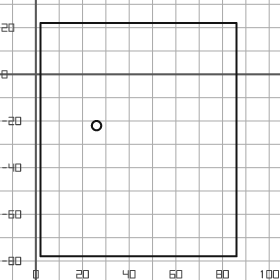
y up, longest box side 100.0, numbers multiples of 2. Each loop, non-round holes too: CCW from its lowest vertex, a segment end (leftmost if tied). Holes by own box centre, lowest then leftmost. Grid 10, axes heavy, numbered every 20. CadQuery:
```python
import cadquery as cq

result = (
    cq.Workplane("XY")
    .moveTo(2.0, -78.0)
    .lineTo(86.0, -78.0)
    .lineTo(86.0, 22.0)
    .lineTo(2.0, 22.0)
    .close()
    .moveTo(26.0, -22.0)
    .circle(2.0)
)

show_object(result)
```